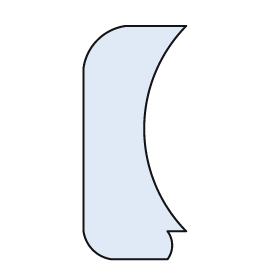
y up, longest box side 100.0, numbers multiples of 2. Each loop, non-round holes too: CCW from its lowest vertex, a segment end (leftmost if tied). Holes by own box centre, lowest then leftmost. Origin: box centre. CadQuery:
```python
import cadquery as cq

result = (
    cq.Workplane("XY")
    .moveTo(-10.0, -50.0)
    .lineTo(14.0, -50.0)
    .threePointArc((16.0, -44.0), (14.0, -38.0))
    .lineTo(22.0, -38.0)
    .threePointArc((4.0, 6.0), (22.0, 50.0))
    .lineTo(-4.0, 50.0)
    .threePointArc((-16.0, 44.0), (-22.0, 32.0))
    .lineTo(-22.0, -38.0)
    .threePointArc((-18.0, -46.0), (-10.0, -50.0))
    .close()
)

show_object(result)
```